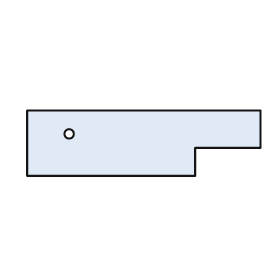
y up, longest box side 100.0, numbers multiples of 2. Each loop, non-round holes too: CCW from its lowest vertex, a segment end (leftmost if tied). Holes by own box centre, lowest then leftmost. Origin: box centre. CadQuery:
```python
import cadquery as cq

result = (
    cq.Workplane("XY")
    .moveTo(-50.0, -14.0)
    .lineTo(22.0, -14.0)
    .lineTo(22.0, -2.0)
    .lineTo(50.0, -2.0)
    .lineTo(50.0, 14.0)
    .lineTo(-50.0, 14.0)
    .close()
    .moveTo(-32.0, 4.0)
    .circle(2.0)
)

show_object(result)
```